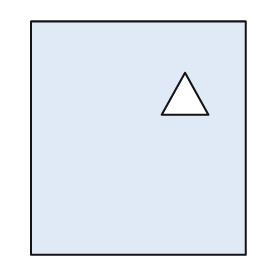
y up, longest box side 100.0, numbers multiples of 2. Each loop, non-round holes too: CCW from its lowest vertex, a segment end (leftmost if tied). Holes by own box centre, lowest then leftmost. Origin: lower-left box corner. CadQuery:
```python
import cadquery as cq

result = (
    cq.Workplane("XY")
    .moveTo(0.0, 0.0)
    .lineTo(92.0, 0.0)
    .lineTo(92.0, 100.0)
    .lineTo(0.0, 100.0)
    .close()
    .moveTo(56.0, 60.0)
    .lineTo(76.0, 60.0)
    .lineTo(66.0, 78.0)
    .close()
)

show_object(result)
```